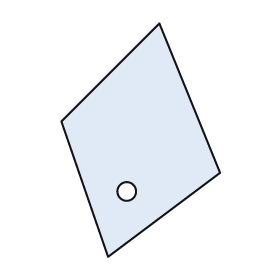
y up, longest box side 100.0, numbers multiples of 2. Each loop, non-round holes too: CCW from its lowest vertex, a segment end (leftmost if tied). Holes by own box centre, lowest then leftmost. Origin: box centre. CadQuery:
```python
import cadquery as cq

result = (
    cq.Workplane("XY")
    .moveTo(-14.0, -50.0)
    .lineTo(34.0, -14.0)
    .lineTo(8.0, 50.0)
    .lineTo(-34.0, 8.0)
    .close()
    .moveTo(-6.0, -22.0)
    .circle(4.0)
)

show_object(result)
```